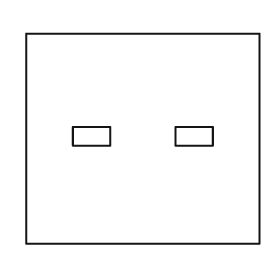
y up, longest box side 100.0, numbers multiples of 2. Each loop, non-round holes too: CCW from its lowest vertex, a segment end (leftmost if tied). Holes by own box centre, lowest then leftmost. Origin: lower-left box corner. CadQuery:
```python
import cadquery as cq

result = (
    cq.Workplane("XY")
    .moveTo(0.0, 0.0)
    .lineTo(100.0, 0.0)
    .lineTo(100.0, 90.0)
    .lineTo(0.0, 90.0)
    .close()
    .moveTo(20.0, 42.0)
    .lineTo(36.0, 42.0)
    .lineTo(36.0, 50.0)
    .lineTo(20.0, 50.0)
    .close()
    .moveTo(64.0, 42.0)
    .lineTo(80.0, 42.0)
    .lineTo(80.0, 50.0)
    .lineTo(64.0, 50.0)
    .close()
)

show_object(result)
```